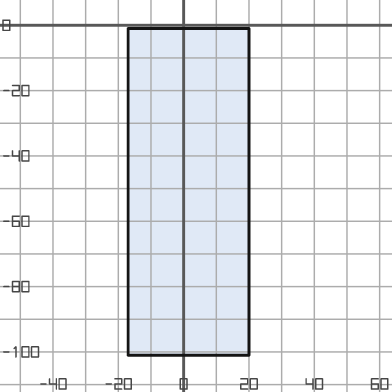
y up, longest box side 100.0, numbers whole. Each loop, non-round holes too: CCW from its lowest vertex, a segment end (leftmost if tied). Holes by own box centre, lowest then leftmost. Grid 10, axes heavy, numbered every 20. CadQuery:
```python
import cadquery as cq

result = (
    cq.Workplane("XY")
    .moveTo(-17.0, -101.0)
    .lineTo(20.0, -101.0)
    .lineTo(20.0, -1.0)
    .lineTo(-17.0, -1.0)
    .close()
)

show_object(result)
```